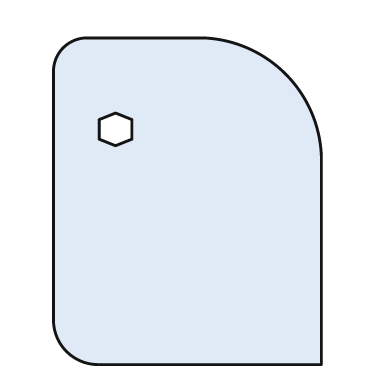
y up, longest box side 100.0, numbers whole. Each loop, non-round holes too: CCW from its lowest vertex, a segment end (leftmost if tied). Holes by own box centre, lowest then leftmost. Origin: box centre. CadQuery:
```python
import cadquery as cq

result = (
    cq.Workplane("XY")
    .moveTo(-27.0, -50.0)
    .lineTo(41.0, -50.0)
    .lineTo(41.0, 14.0)
    .threePointArc((30.0, 39.0), (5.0, 50.0))
    .lineTo(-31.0, 50.0)
    .threePointArc((-38.0, 47.0), (-41.0, 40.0))
    .lineTo(-41.0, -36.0)
    .threePointArc((-37.0, -46.0), (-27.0, -50.0))
    .close()
    .moveTo(-22.0, 17.0)
    .lineTo(-17.0, 19.0)
    .lineTo(-17.0, 25.0)
    .lineTo(-22.0, 27.0)
    .lineTo(-27.0, 25.0)
    .lineTo(-27.0, 19.0)
    .close()
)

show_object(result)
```